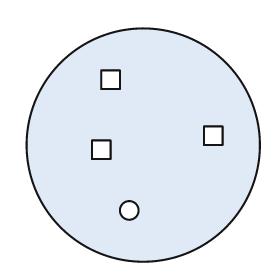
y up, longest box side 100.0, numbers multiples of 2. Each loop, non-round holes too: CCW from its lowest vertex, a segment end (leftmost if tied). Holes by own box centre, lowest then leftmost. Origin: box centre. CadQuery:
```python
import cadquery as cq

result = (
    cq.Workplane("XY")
    .moveTo(0.0, 0.0)
    .circle(50.0)
    .moveTo(-6.0, -28.0)
    .circle(4.0)
    .moveTo(-22.0, -6.0)
    .lineTo(-14.0, -6.0)
    .lineTo(-14.0, 2.0)
    .lineTo(-22.0, 2.0)
    .close()
    .moveTo(26.0, 0.0)
    .lineTo(34.0, 0.0)
    .lineTo(34.0, 8.0)
    .lineTo(26.0, 8.0)
    .close()
    .moveTo(-18.0, 24.0)
    .lineTo(-10.0, 24.0)
    .lineTo(-10.0, 32.0)
    .lineTo(-18.0, 32.0)
    .close()
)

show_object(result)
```